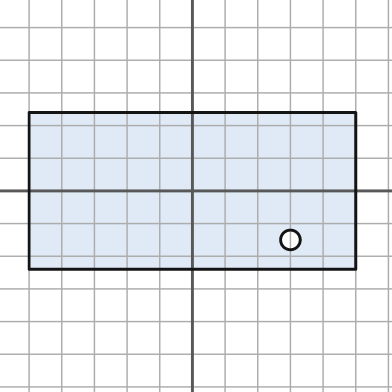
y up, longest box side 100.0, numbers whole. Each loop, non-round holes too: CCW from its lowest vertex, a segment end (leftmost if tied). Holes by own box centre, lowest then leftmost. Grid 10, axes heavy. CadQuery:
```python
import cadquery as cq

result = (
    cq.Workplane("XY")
    .moveTo(-50.0, -24.0)
    .lineTo(50.0, -24.0)
    .lineTo(50.0, 24.0)
    .lineTo(-50.0, 24.0)
    .close()
    .moveTo(30.0, -15.0)
    .circle(3.0)
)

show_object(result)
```